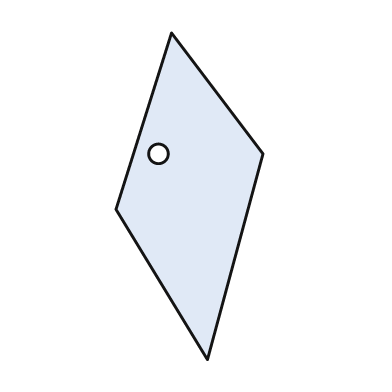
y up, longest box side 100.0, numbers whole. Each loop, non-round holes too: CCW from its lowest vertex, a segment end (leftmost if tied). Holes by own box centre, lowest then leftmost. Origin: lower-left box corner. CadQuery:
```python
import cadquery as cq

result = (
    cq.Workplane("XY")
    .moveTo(28.0, 0.0)
    .lineTo(45.0, 63.0)
    .lineTo(17.0, 100.0)
    .lineTo(0.0, 46.0)
    .close()
    .moveTo(13.0, 63.0)
    .circle(3.0)
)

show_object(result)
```